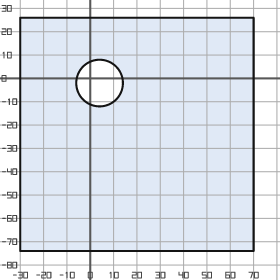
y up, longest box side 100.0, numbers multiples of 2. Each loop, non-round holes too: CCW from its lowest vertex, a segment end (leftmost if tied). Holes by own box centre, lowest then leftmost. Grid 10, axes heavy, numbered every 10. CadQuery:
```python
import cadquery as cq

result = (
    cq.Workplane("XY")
    .moveTo(-30.0, -74.0)
    .lineTo(70.0, -74.0)
    .lineTo(70.0, 26.0)
    .lineTo(-30.0, 26.0)
    .close()
    .moveTo(4.0, -2.0)
    .circle(10.0)
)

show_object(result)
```